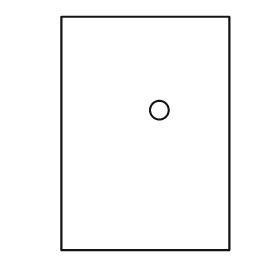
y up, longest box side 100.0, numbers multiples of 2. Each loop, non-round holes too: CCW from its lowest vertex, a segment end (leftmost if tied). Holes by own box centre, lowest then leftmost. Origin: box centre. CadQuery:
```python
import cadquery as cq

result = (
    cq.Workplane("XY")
    .moveTo(-36.0, -50.0)
    .lineTo(36.0, -50.0)
    .lineTo(36.0, 50.0)
    .lineTo(-36.0, 50.0)
    .close()
    .moveTo(6.0, 10.0)
    .circle(4.0)
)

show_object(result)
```